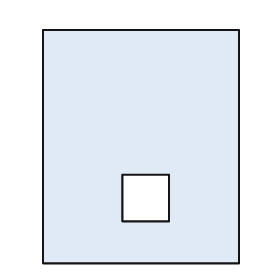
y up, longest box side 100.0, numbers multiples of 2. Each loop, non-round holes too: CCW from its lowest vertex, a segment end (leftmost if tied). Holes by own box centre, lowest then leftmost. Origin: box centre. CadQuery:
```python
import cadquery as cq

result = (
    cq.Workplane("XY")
    .moveTo(-42.0, -50.0)
    .lineTo(42.0, -50.0)
    .lineTo(42.0, 50.0)
    .lineTo(-42.0, 50.0)
    .close()
    .moveTo(-8.0, -32.0)
    .lineTo(12.0, -32.0)
    .lineTo(12.0, -12.0)
    .lineTo(-8.0, -12.0)
    .close()
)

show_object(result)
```